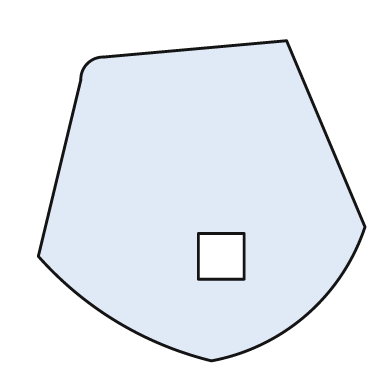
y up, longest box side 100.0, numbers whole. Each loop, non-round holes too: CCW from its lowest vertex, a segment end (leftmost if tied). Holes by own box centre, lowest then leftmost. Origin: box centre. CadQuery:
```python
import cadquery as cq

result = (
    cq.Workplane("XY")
    .moveTo(3.0, -49.0)
    .threePointArc((32.0, -35.0), (50.0, -8.0))
    .lineTo(26.0, 49.0)
    .lineTo(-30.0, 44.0)
    .threePointArc((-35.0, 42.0), (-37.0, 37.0))
    .lineTo(-50.0, -17.0)
    .threePointArc((-26.0, -37.0), (3.0, -49.0))
    .close()
    .moveTo(-1.0, -24.0)
    .lineTo(13.0, -24.0)
    .lineTo(13.0, -10.0)
    .lineTo(-1.0, -10.0)
    .close()
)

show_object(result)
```